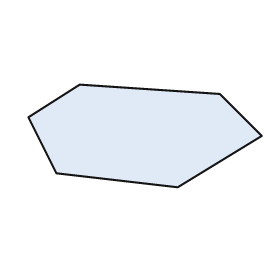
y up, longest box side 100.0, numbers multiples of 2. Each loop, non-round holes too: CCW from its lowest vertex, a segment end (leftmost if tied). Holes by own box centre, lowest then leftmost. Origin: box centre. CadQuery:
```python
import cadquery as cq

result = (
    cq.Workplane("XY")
    .moveTo(14.0, -22.0)
    .lineTo(50.0, 0.0)
    .lineTo(32.0, 18.0)
    .lineTo(-28.0, 22.0)
    .lineTo(-50.0, 8.0)
    .lineTo(-38.0, -16.0)
    .close()
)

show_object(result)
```